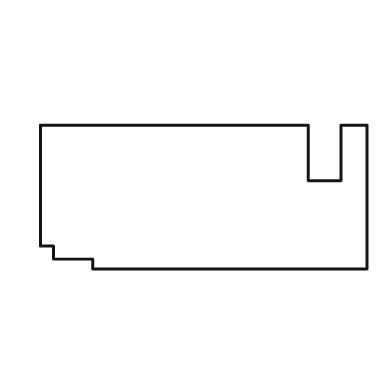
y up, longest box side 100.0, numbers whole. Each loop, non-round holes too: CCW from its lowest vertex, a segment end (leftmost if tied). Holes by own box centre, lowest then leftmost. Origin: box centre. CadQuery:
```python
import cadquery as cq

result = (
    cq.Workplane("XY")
    .moveTo(-34.0, -22.0)
    .lineTo(50.0, -22.0)
    .lineTo(50.0, 22.0)
    .lineTo(42.0, 22.0)
    .lineTo(42.0, 5.0)
    .lineTo(32.0, 5.0)
    .lineTo(32.0, 22.0)
    .lineTo(-50.0, 22.0)
    .lineTo(-50.0, -15.0)
    .lineTo(-46.0, -15.0)
    .lineTo(-46.0, -19.0)
    .lineTo(-34.0, -19.0)
    .close()
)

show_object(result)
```